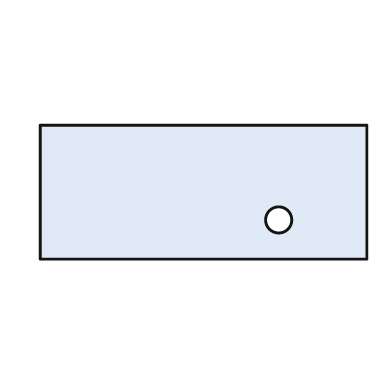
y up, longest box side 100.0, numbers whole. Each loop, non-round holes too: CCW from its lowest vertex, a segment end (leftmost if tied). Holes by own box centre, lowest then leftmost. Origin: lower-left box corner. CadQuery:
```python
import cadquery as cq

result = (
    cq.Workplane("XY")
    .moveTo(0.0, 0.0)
    .lineTo(100.0, 0.0)
    .lineTo(100.0, 41.0)
    .lineTo(0.0, 41.0)
    .close()
    .moveTo(73.0, 12.0)
    .circle(4.0)
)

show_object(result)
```